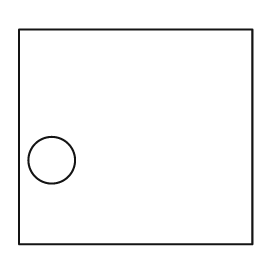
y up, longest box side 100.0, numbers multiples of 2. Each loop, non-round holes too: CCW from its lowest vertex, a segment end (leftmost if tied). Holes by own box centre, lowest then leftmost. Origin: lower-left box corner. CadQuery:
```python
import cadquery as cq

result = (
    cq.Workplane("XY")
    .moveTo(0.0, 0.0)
    .lineTo(100.0, 0.0)
    .lineTo(100.0, 92.0)
    .lineTo(0.0, 92.0)
    .close()
    .moveTo(14.0, 36.0)
    .circle(10.0)
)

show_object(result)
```